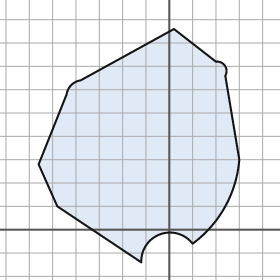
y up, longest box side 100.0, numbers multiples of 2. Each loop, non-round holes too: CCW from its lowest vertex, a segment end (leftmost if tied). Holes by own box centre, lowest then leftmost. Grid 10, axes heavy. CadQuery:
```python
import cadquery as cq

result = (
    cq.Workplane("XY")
    .moveTo(-12.0, -14.0)
    .threePointArc((-4.0, -2.0), (10.0, -6.0))
    .threePointArc((24.0, 10.0), (30.0, 30.0))
    .lineTo(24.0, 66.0)
    .threePointArc((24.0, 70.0), (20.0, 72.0))
    .lineTo(2.0, 86.0)
    .lineTo(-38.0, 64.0)
    .threePointArc((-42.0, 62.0), (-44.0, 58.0))
    .lineTo(-56.0, 28.0)
    .lineTo(-48.0, 10.0)
    .close()
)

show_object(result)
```